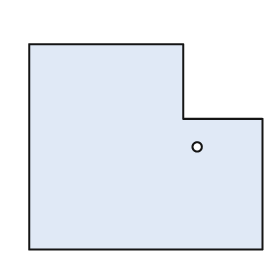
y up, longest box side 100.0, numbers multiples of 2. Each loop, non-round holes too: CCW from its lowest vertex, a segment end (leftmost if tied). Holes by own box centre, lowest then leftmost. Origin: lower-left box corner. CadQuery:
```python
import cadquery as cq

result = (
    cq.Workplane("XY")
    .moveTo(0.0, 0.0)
    .lineTo(100.0, 0.0)
    .lineTo(100.0, 56.0)
    .lineTo(66.0, 56.0)
    .lineTo(66.0, 88.0)
    .lineTo(0.0, 88.0)
    .close()
    .moveTo(72.0, 44.0)
    .circle(2.0)
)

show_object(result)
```